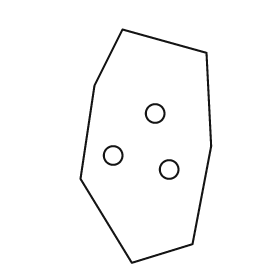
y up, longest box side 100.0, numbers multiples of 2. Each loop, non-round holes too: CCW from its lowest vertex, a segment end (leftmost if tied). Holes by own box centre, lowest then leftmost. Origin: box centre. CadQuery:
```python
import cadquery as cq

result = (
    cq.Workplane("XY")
    .moveTo(-6.0, -50.0)
    .lineTo(20.0, -42.0)
    .lineTo(28.0, 0.0)
    .lineTo(26.0, 40.0)
    .lineTo(-10.0, 50.0)
    .lineTo(-22.0, 26.0)
    .lineTo(-28.0, -14.0)
    .close()
    .moveTo(10.0, -10.0)
    .circle(4.0)
    .moveTo(-14.0, -4.0)
    .circle(4.0)
    .moveTo(4.0, 14.0)
    .circle(4.0)
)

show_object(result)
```